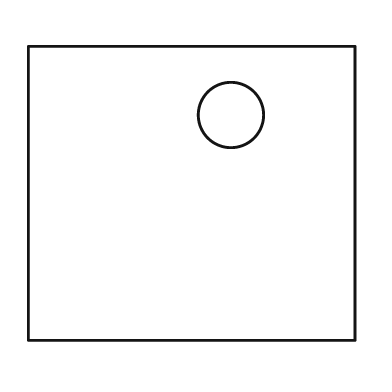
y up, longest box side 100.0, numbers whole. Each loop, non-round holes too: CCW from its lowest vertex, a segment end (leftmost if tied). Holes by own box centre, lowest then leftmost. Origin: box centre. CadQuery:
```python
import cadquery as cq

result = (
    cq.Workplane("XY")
    .moveTo(-50.0, -45.0)
    .lineTo(50.0, -45.0)
    .lineTo(50.0, 45.0)
    .lineTo(-50.0, 45.0)
    .close()
    .moveTo(12.0, 24.0)
    .circle(10.0)
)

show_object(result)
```